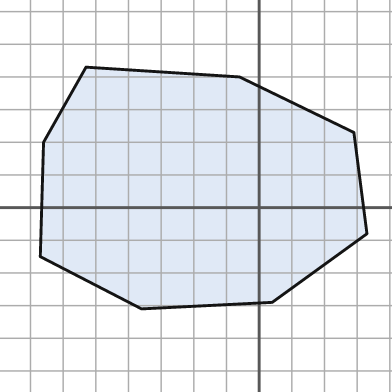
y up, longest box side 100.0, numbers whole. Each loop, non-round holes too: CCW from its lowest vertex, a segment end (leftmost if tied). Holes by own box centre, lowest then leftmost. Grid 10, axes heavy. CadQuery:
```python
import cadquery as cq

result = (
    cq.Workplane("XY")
    .moveTo(-36.0, -31.0)
    .lineTo(4.0, -29.0)
    .lineTo(33.0, -8.0)
    .lineTo(29.0, 23.0)
    .lineTo(-6.0, 40.0)
    .lineTo(-53.0, 43.0)
    .lineTo(-66.0, 20.0)
    .lineTo(-67.0, -15.0)
    .close()
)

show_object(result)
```